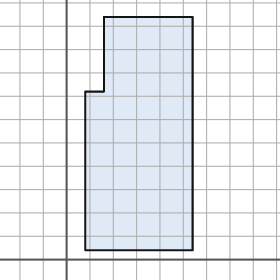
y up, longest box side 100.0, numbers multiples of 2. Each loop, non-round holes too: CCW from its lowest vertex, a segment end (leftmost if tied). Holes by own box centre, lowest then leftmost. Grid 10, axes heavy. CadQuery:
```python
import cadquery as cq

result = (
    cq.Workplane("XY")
    .moveTo(8.0, 4.0)
    .lineTo(54.0, 4.0)
    .lineTo(54.0, 104.0)
    .lineTo(16.0, 104.0)
    .lineTo(16.0, 72.0)
    .lineTo(8.0, 72.0)
    .close()
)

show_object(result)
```